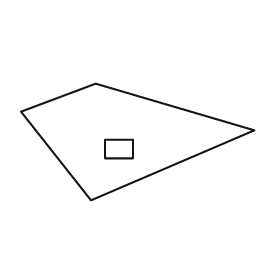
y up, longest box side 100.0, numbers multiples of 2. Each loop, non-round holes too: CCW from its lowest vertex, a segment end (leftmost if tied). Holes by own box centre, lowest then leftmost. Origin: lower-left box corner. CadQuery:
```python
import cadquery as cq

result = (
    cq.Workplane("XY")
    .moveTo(30.0, 0.0)
    .lineTo(100.0, 30.0)
    .lineTo(32.0, 50.0)
    .lineTo(0.0, 38.0)
    .close()
    .moveTo(36.0, 18.0)
    .lineTo(48.0, 18.0)
    .lineTo(48.0, 26.0)
    .lineTo(36.0, 26.0)
    .close()
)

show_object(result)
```